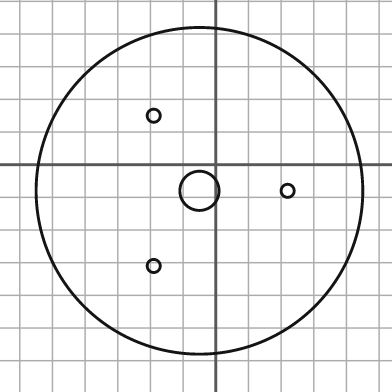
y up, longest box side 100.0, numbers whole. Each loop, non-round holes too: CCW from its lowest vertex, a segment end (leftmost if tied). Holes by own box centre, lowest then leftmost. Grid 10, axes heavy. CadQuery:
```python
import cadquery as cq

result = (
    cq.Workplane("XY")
    .moveTo(-5.0, -8.0)
    .circle(50.0)
    .moveTo(-19.0, -31.0)
    .circle(2.0)
    .moveTo(-5.0, -8.0)
    .circle(6.0)
    .moveTo(22.0, -8.0)
    .circle(2.0)
    .moveTo(-19.0, 15.0)
    .circle(2.0)
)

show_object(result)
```